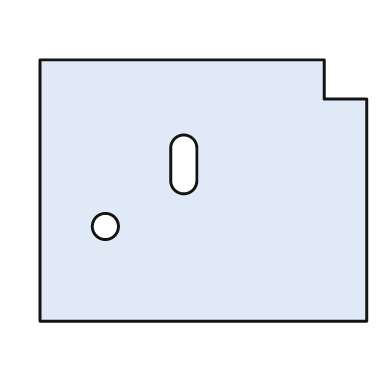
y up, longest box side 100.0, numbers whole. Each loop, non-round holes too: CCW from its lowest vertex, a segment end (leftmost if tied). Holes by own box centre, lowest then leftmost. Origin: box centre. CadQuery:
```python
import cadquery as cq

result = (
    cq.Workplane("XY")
    .moveTo(-50.0, -40.0)
    .lineTo(50.0, -40.0)
    .lineTo(50.0, 28.0)
    .lineTo(37.0, 28.0)
    .lineTo(37.0, 40.0)
    .lineTo(-50.0, 40.0)
    .close()
    .moveTo(-30.0, -11.0)
    .circle(4.0)
    .moveTo(-10.0, 3.0)
    .threePointArc((-6.0, -1.0), (-2.0, 3.0))
    .lineTo(-2.0, 13.0)
    .threePointArc((-6.0, 17.0), (-10.0, 13.0))
    .close()
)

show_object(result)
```